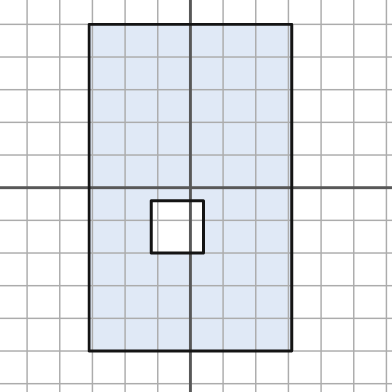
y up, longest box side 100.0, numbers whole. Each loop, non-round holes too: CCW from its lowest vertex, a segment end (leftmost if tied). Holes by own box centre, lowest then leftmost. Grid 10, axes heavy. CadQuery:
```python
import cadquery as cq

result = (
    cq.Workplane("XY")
    .moveTo(-31.0, -50.0)
    .lineTo(31.0, -50.0)
    .lineTo(31.0, 50.0)
    .lineTo(-31.0, 50.0)
    .close()
    .moveTo(-12.0, -20.0)
    .lineTo(4.0, -20.0)
    .lineTo(4.0, -4.0)
    .lineTo(-12.0, -4.0)
    .close()
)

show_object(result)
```